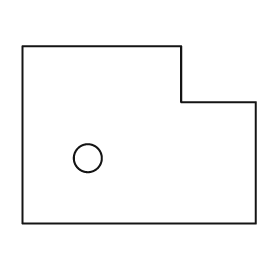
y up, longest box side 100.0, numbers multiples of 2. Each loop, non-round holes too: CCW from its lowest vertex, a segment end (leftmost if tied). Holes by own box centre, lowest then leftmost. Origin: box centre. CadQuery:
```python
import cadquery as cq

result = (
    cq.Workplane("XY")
    .moveTo(-50.0, -38.0)
    .lineTo(50.0, -38.0)
    .lineTo(50.0, 14.0)
    .lineTo(18.0, 14.0)
    .lineTo(18.0, 38.0)
    .lineTo(-50.0, 38.0)
    .close()
    .moveTo(-22.0, -10.0)
    .circle(6.0)
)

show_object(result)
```